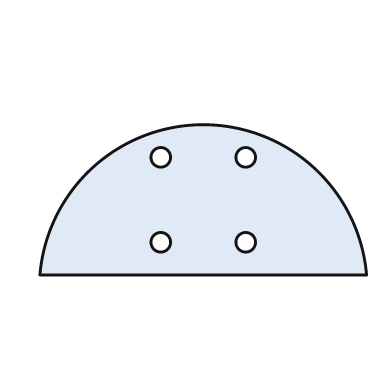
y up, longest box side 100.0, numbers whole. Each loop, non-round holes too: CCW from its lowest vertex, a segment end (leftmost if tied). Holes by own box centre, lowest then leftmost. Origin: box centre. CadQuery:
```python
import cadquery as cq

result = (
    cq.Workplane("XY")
    .moveTo(-50.0, -23.0)
    .lineTo(50.0, -23.0)
    .threePointArc((0.0, 23.0), (-50.0, -23.0))
    .close()
    .moveTo(-13.0, -13.0)
    .circle(3.0)
    .moveTo(13.0, -13.0)
    .circle(3.0)
    .moveTo(-13.0, 13.0)
    .circle(3.0)
    .moveTo(13.0, 13.0)
    .circle(3.0)
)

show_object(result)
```